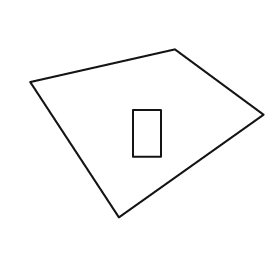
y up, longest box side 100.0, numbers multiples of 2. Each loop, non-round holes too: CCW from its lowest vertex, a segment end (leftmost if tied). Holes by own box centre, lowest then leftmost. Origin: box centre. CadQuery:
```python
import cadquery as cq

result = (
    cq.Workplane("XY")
    .moveTo(-12.0, -36.0)
    .lineTo(50.0, 8.0)
    .lineTo(12.0, 36.0)
    .lineTo(-50.0, 22.0)
    .close()
    .moveTo(-6.0, -10.0)
    .lineTo(6.0, -10.0)
    .lineTo(6.0, 10.0)
    .lineTo(-6.0, 10.0)
    .close()
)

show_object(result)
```